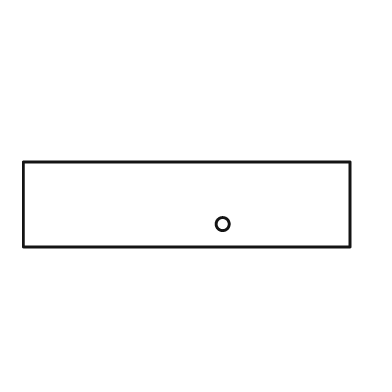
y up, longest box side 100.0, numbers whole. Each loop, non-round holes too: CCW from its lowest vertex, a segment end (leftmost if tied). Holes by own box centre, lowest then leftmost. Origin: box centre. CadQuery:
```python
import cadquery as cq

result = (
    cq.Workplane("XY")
    .moveTo(-50.0, -13.0)
    .lineTo(50.0, -13.0)
    .lineTo(50.0, 13.0)
    .lineTo(-50.0, 13.0)
    .close()
    .moveTo(11.0, -6.0)
    .circle(2.0)
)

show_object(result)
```